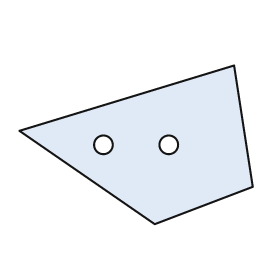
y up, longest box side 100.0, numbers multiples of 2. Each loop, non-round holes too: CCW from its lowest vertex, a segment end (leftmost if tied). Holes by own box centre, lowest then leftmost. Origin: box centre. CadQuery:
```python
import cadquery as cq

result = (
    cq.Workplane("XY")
    .moveTo(8.0, -34.0)
    .lineTo(50.0, -18.0)
    .lineTo(42.0, 34.0)
    .lineTo(-50.0, 6.0)
    .close()
    .moveTo(-14.0, 0.0)
    .circle(4.0)
    .moveTo(14.0, 0.0)
    .circle(4.0)
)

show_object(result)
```